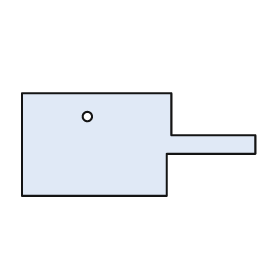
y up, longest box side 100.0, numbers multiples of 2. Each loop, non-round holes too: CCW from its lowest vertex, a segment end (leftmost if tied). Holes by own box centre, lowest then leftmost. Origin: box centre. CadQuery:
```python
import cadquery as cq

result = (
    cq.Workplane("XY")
    .moveTo(-50.0, -22.0)
    .lineTo(12.0, -22.0)
    .lineTo(12.0, -4.0)
    .lineTo(50.0, -4.0)
    .lineTo(50.0, 4.0)
    .lineTo(14.0, 4.0)
    .lineTo(14.0, 22.0)
    .lineTo(-50.0, 22.0)
    .close()
    .moveTo(-22.0, 12.0)
    .circle(2.0)
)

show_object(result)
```